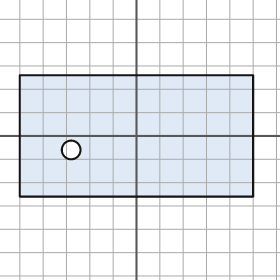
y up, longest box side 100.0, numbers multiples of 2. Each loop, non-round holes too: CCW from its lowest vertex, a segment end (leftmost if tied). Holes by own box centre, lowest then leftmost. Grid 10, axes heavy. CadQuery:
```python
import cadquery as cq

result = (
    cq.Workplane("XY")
    .moveTo(-50.0, -26.0)
    .lineTo(50.0, -26.0)
    .lineTo(50.0, 26.0)
    .lineTo(-50.0, 26.0)
    .close()
    .moveTo(-28.0, -6.0)
    .circle(4.0)
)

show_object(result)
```